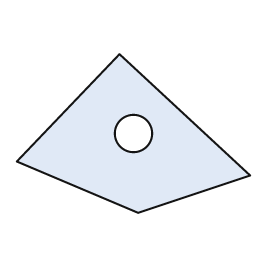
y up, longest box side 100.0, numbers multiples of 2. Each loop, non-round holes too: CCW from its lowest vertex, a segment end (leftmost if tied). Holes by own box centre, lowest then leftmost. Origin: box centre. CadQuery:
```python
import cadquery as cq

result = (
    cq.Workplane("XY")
    .moveTo(2.0, -34.0)
    .lineTo(50.0, -18.0)
    .lineTo(-6.0, 34.0)
    .lineTo(-50.0, -12.0)
    .close()
    .moveTo(0.0, 0.0)
    .circle(8.0)
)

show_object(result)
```